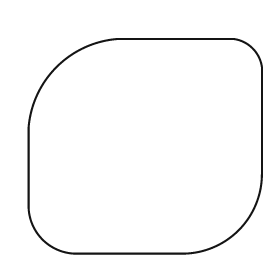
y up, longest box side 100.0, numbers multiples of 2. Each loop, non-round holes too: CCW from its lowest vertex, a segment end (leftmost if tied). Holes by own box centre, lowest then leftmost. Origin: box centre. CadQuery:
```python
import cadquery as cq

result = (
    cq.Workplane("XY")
    .moveTo(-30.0, -46.0)
    .lineTo(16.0, -46.0)
    .threePointArc((40.0, -36.0), (50.0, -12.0))
    .lineTo(50.0, 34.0)
    .threePointArc((46.0, 42.0), (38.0, 46.0))
    .lineTo(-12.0, 46.0)
    .threePointArc((-38.0, 34.0), (-50.0, 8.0))
    .lineTo(-50.0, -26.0)
    .threePointArc((-44.0, -40.0), (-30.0, -46.0))
    .close()
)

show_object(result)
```